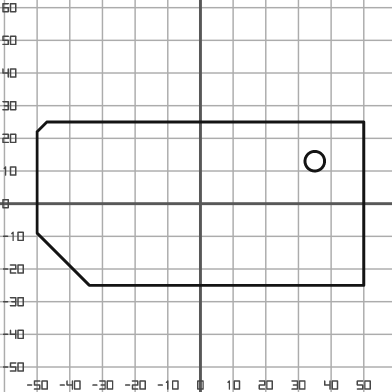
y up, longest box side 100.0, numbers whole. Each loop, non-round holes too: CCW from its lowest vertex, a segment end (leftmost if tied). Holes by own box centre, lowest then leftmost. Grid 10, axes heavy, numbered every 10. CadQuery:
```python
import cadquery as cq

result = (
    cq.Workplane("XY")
    .moveTo(-34.0, -25.0)
    .lineTo(50.0, -25.0)
    .lineTo(50.0, 25.0)
    .lineTo(-47.0, 25.0)
    .lineTo(-50.0, 22.0)
    .lineTo(-50.0, -9.0)
    .close()
    .moveTo(35.0, 13.0)
    .circle(3.0)
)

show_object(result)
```